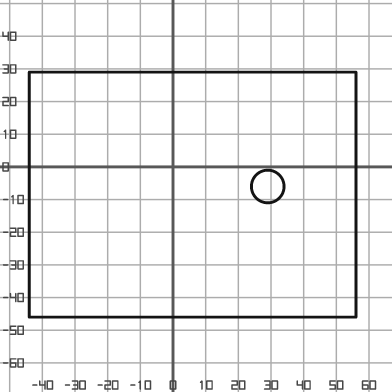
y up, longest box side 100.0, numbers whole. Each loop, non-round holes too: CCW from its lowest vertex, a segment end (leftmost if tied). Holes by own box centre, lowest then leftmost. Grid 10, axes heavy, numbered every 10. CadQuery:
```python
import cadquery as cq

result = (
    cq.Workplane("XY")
    .moveTo(-44.0, -46.0)
    .lineTo(56.0, -46.0)
    .lineTo(56.0, 29.0)
    .lineTo(-44.0, 29.0)
    .close()
    .moveTo(29.0, -6.0)
    .circle(5.0)
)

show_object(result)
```